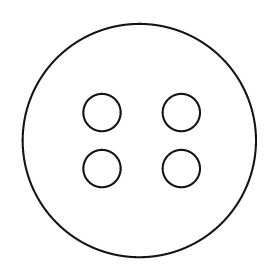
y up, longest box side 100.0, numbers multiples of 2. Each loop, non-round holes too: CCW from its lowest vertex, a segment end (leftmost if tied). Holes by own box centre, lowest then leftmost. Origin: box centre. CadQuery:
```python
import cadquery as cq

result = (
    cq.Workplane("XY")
    .moveTo(0.0, 0.0)
    .circle(50.0)
    .moveTo(-16.0, -12.0)
    .circle(8.0)
    .moveTo(18.0, -12.0)
    .circle(8.0)
    .moveTo(-16.0, 12.0)
    .circle(8.0)
    .moveTo(18.0, 12.0)
    .circle(8.0)
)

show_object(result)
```